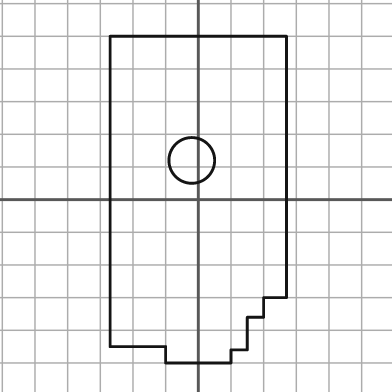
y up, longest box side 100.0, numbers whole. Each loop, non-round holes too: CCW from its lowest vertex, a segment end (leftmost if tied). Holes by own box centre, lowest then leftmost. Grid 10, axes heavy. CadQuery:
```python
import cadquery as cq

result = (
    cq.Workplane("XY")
    .moveTo(-10.0, -50.0)
    .lineTo(10.0, -50.0)
    .lineTo(10.0, -46.0)
    .lineTo(15.0, -46.0)
    .lineTo(15.0, -36.0)
    .lineTo(20.0, -36.0)
    .lineTo(20.0, -30.0)
    .lineTo(27.0, -30.0)
    .lineTo(27.0, 50.0)
    .lineTo(-27.0, 50.0)
    .lineTo(-27.0, -45.0)
    .lineTo(-10.0, -45.0)
    .close()
    .moveTo(-2.0, 12.0)
    .circle(7.0)
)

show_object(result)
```